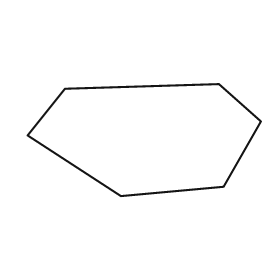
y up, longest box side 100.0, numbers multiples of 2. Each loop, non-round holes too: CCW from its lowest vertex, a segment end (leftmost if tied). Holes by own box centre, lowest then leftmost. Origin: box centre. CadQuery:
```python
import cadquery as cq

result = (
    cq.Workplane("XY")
    .moveTo(-10.0, -24.0)
    .lineTo(34.0, -20.0)
    .lineTo(50.0, 8.0)
    .lineTo(32.0, 24.0)
    .lineTo(-34.0, 22.0)
    .lineTo(-50.0, 2.0)
    .close()
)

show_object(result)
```